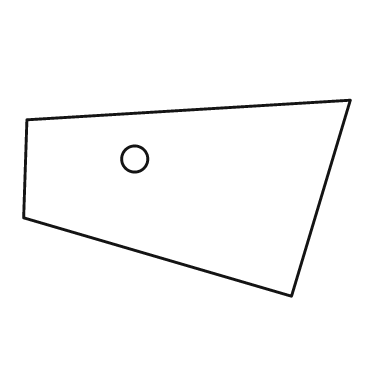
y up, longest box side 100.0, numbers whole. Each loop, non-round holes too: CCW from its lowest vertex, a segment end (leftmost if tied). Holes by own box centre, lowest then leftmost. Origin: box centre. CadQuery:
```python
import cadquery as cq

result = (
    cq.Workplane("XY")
    .moveTo(32.0, -30.0)
    .lineTo(50.0, 30.0)
    .lineTo(-49.0, 24.0)
    .lineTo(-50.0, -6.0)
    .close()
    .moveTo(-16.0, 12.0)
    .circle(4.0)
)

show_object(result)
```